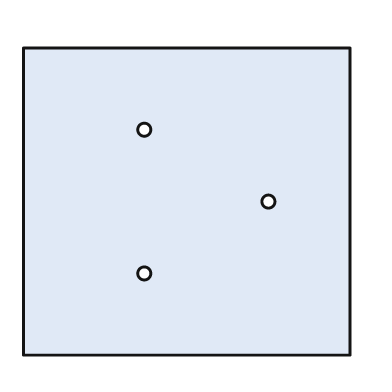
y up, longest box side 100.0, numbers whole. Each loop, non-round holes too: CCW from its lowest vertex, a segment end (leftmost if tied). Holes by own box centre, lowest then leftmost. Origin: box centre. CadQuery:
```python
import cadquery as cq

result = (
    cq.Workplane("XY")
    .moveTo(-50.0, -47.0)
    .lineTo(50.0, -47.0)
    .lineTo(50.0, 47.0)
    .lineTo(-50.0, 47.0)
    .close()
    .moveTo(-13.0, -22.0)
    .circle(2.0)
    .moveTo(25.0, 0.0)
    .circle(2.0)
    .moveTo(-13.0, 22.0)
    .circle(2.0)
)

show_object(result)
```